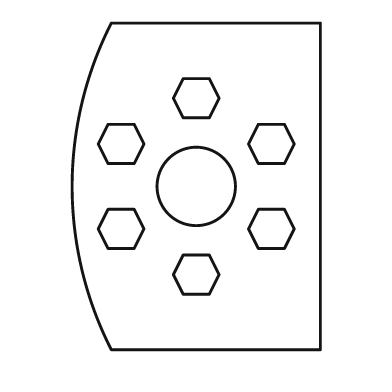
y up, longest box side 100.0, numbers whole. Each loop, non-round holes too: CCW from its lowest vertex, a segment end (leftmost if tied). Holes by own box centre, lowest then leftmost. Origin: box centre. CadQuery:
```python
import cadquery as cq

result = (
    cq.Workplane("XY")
    .moveTo(-26.0, -50.0)
    .lineTo(38.0, -50.0)
    .lineTo(38.0, 50.0)
    .lineTo(-26.0, 50.0)
    .threePointArc((-38.0, 0.0), (-26.0, -50.0))
    .close()
    .moveTo(-4.0, -33.0)
    .lineTo(4.0, -33.0)
    .lineTo(7.0, -27.0)
    .lineTo(4.0, -21.0)
    .lineTo(-4.0, -21.0)
    .lineTo(-7.0, -27.0)
    .close()
    .moveTo(-27.0, -19.0)
    .lineTo(-19.0, -19.0)
    .lineTo(-16.0, -13.0)
    .lineTo(-19.0, -7.0)
    .lineTo(-27.0, -7.0)
    .lineTo(-30.0, -13.0)
    .close()
    .moveTo(19.0, -19.0)
    .lineTo(27.0, -19.0)
    .lineTo(30.0, -13.0)
    .lineTo(27.0, -7.0)
    .lineTo(19.0, -7.0)
    .lineTo(16.0, -13.0)
    .close()
    .moveTo(0.0, 0.0)
    .circle(12.0)
    .moveTo(-27.0, 7.0)
    .lineTo(-19.0, 7.0)
    .lineTo(-16.0, 13.0)
    .lineTo(-19.0, 19.0)
    .lineTo(-27.0, 19.0)
    .lineTo(-30.0, 13.0)
    .close()
    .moveTo(19.0, 7.0)
    .lineTo(27.0, 7.0)
    .lineTo(30.0, 13.0)
    .lineTo(27.0, 19.0)
    .lineTo(19.0, 19.0)
    .lineTo(16.0, 13.0)
    .close()
    .moveTo(-4.0, 21.0)
    .lineTo(4.0, 21.0)
    .lineTo(7.0, 27.0)
    .lineTo(4.0, 33.0)
    .lineTo(-4.0, 33.0)
    .lineTo(-7.0, 27.0)
    .close()
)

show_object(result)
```